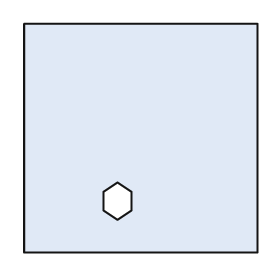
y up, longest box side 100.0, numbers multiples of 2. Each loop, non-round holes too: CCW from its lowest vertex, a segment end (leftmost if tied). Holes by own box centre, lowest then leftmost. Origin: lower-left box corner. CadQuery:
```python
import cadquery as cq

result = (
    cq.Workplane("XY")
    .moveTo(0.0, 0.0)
    .lineTo(100.0, 0.0)
    .lineTo(100.0, 98.0)
    .lineTo(0.0, 98.0)
    .close()
    .moveTo(40.0, 14.0)
    .lineTo(46.0, 18.0)
    .lineTo(46.0, 26.0)
    .lineTo(40.0, 30.0)
    .lineTo(34.0, 26.0)
    .lineTo(34.0, 18.0)
    .close()
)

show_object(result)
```